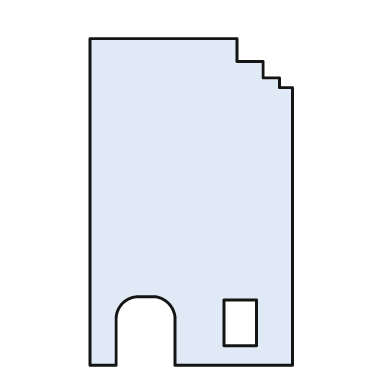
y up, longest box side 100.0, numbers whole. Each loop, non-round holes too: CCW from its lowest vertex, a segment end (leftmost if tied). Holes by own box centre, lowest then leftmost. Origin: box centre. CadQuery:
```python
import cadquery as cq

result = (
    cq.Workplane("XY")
    .moveTo(-31.0, -50.0)
    .lineTo(-23.0, -50.0)
    .lineTo(-23.0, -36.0)
    .threePointArc((-21.0, -31.0), (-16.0, -29.0))
    .lineTo(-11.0, -29.0)
    .threePointArc((-7.0, -31.0), (-5.0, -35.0))
    .lineTo(-5.0, -50.0)
    .lineTo(31.0, -50.0)
    .lineTo(31.0, 35.0)
    .lineTo(27.0, 35.0)
    .lineTo(27.0, 38.0)
    .lineTo(22.0, 38.0)
    .lineTo(22.0, 43.0)
    .lineTo(14.0, 43.0)
    .lineTo(14.0, 50.0)
    .lineTo(-31.0, 50.0)
    .close()
    .moveTo(10.0, -44.0)
    .lineTo(20.0, -44.0)
    .lineTo(20.0, -30.0)
    .lineTo(10.0, -30.0)
    .close()
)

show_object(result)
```